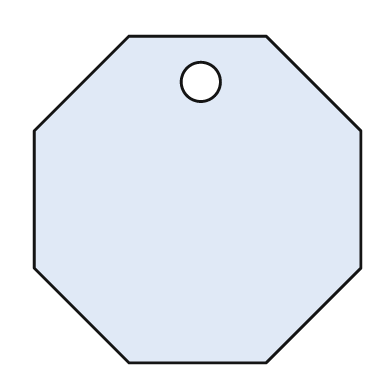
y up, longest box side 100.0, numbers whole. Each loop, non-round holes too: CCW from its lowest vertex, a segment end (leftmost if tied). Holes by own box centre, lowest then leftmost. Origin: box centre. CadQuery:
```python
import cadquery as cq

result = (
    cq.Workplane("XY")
    .moveTo(-21.0, -50.0)
    .lineTo(21.0, -50.0)
    .lineTo(50.0, -21.0)
    .lineTo(50.0, 21.0)
    .lineTo(21.0, 50.0)
    .lineTo(-21.0, 50.0)
    .lineTo(-50.0, 21.0)
    .lineTo(-50.0, -21.0)
    .close()
    .moveTo(1.0, 36.0)
    .circle(6.0)
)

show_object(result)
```